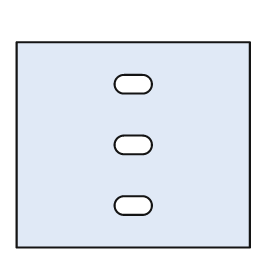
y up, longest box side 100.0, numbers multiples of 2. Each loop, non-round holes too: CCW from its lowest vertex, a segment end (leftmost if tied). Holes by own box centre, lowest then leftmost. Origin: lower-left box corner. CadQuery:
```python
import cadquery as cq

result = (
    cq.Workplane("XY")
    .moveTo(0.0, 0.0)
    .lineTo(100.0, 0.0)
    .lineTo(100.0, 88.0)
    .lineTo(0.0, 88.0)
    .close()
    .moveTo(46.0, 14.0)
    .lineTo(54.0, 14.0)
    .threePointArc((58.0, 18.0), (54.0, 22.0))
    .lineTo(46.0, 22.0)
    .threePointArc((42.0, 18.0), (46.0, 14.0))
    .close()
    .moveTo(46.0, 40.0)
    .lineTo(54.0, 40.0)
    .threePointArc((58.0, 44.0), (54.0, 48.0))
    .lineTo(46.0, 48.0)
    .threePointArc((42.0, 44.0), (46.0, 40.0))
    .close()
    .moveTo(46.0, 66.0)
    .lineTo(54.0, 66.0)
    .threePointArc((58.0, 70.0), (54.0, 74.0))
    .lineTo(46.0, 74.0)
    .threePointArc((42.0, 70.0), (46.0, 66.0))
    .close()
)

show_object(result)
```